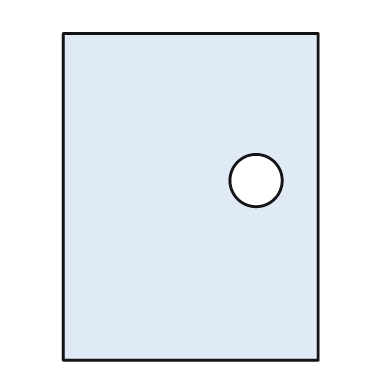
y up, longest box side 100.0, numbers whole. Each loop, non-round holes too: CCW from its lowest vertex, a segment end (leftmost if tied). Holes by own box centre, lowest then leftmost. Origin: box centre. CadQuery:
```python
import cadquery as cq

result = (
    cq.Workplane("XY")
    .moveTo(-39.0, -50.0)
    .lineTo(39.0, -50.0)
    .lineTo(39.0, 50.0)
    .lineTo(-39.0, 50.0)
    .close()
    .moveTo(20.0, 5.0)
    .circle(8.0)
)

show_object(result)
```